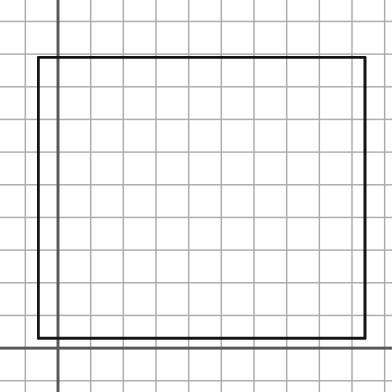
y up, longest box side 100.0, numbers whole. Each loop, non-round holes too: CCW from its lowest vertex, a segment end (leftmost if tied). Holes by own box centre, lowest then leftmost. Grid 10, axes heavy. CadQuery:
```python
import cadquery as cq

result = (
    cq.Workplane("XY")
    .moveTo(-6.0, 3.0)
    .lineTo(94.0, 3.0)
    .lineTo(94.0, 89.0)
    .lineTo(-6.0, 89.0)
    .close()
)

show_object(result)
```